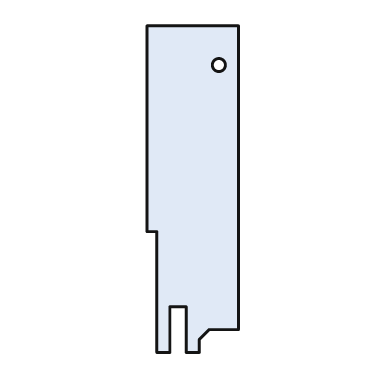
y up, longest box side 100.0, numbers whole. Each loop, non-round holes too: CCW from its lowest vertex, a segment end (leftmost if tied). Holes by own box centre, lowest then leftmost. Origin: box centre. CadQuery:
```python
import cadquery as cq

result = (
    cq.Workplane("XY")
    .moveTo(-11.0, -50.0)
    .lineTo(-7.0, -50.0)
    .lineTo(-7.0, -36.0)
    .lineTo(-2.0, -36.0)
    .lineTo(-2.0, -50.0)
    .lineTo(2.0, -50.0)
    .lineTo(2.0, -46.0)
    .lineTo(5.0, -43.0)
    .lineTo(14.0, -43.0)
    .lineTo(14.0, 50.0)
    .lineTo(-14.0, 50.0)
    .lineTo(-14.0, -13.0)
    .lineTo(-11.0, -13.0)
    .close()
    .moveTo(8.0, 38.0)
    .circle(2.0)
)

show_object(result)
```